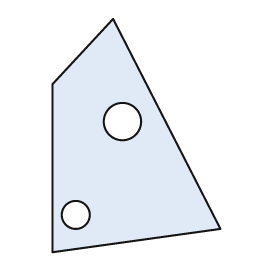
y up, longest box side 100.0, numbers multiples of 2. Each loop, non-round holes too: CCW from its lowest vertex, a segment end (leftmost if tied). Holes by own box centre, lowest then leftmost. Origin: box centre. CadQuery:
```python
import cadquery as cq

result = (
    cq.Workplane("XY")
    .moveTo(-36.0, -50.0)
    .lineTo(36.0, -40.0)
    .lineTo(-10.0, 50.0)
    .lineTo(-36.0, 22.0)
    .close()
    .moveTo(-26.0, -34.0)
    .circle(6.0)
    .moveTo(-6.0, 6.0)
    .circle(8.0)
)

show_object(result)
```